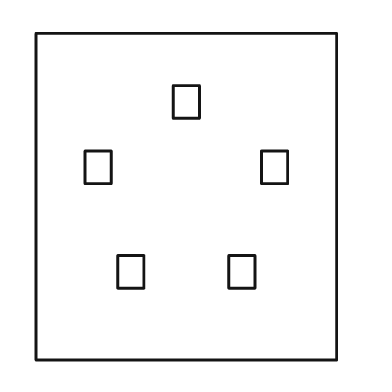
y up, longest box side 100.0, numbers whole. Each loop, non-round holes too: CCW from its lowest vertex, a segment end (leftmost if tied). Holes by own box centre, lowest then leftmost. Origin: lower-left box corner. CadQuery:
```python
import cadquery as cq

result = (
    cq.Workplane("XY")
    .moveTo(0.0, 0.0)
    .lineTo(92.0, 0.0)
    .lineTo(92.0, 100.0)
    .lineTo(0.0, 100.0)
    .close()
    .moveTo(25.0, 22.0)
    .lineTo(33.0, 22.0)
    .lineTo(33.0, 32.0)
    .lineTo(25.0, 32.0)
    .close()
    .moveTo(59.0, 22.0)
    .lineTo(67.0, 22.0)
    .lineTo(67.0, 32.0)
    .lineTo(59.0, 32.0)
    .close()
    .moveTo(15.0, 54.0)
    .lineTo(23.0, 54.0)
    .lineTo(23.0, 64.0)
    .lineTo(15.0, 64.0)
    .close()
    .moveTo(69.0, 54.0)
    .lineTo(77.0, 54.0)
    .lineTo(77.0, 64.0)
    .lineTo(69.0, 64.0)
    .close()
    .moveTo(42.0, 74.0)
    .lineTo(50.0, 74.0)
    .lineTo(50.0, 84.0)
    .lineTo(42.0, 84.0)
    .close()
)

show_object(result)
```